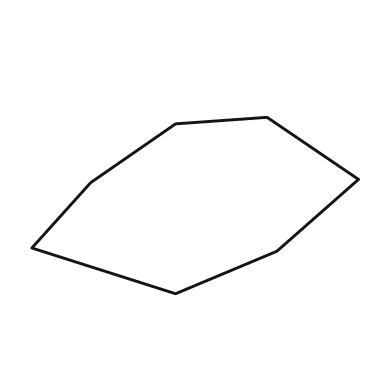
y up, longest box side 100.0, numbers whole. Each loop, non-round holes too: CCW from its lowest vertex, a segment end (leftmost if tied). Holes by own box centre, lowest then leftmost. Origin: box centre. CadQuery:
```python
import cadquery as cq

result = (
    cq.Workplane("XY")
    .moveTo(-6.0, -27.0)
    .lineTo(25.0, -14.0)
    .lineTo(50.0, 8.0)
    .lineTo(22.0, 27.0)
    .lineTo(-6.0, 25.0)
    .lineTo(-32.0, 7.0)
    .lineTo(-50.0, -13.0)
    .close()
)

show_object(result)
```